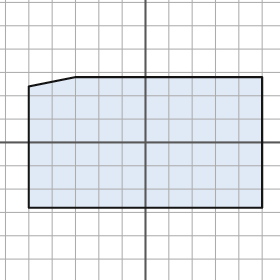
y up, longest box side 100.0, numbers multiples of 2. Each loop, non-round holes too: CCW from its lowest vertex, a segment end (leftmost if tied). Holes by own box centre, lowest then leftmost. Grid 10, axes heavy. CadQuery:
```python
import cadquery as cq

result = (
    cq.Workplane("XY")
    .moveTo(-50.0, -28.0)
    .lineTo(50.0, -28.0)
    .lineTo(50.0, 28.0)
    .lineTo(-30.0, 28.0)
    .lineTo(-50.0, 24.0)
    .close()
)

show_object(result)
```